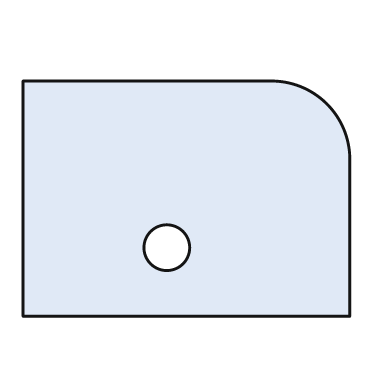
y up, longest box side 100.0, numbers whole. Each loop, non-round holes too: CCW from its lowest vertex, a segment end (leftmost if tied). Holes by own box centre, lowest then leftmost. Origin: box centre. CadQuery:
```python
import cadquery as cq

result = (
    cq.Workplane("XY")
    .moveTo(-50.0, -36.0)
    .lineTo(50.0, -36.0)
    .lineTo(50.0, 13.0)
    .threePointArc((43.0, 29.0), (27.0, 36.0))
    .lineTo(-50.0, 36.0)
    .close()
    .moveTo(-6.0, -15.0)
    .circle(7.0)
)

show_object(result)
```